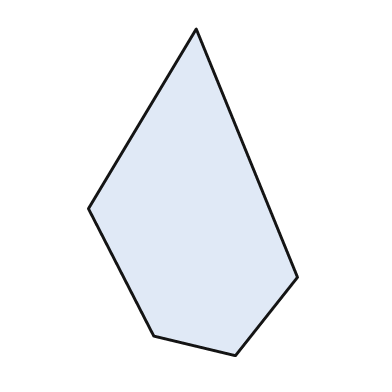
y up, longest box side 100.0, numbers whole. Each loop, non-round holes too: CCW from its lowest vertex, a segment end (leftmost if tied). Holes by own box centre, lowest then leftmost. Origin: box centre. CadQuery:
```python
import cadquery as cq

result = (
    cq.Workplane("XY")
    .moveTo(13.0, -50.0)
    .lineTo(32.0, -26.0)
    .lineTo(1.0, 50.0)
    .lineTo(-32.0, -5.0)
    .lineTo(-12.0, -44.0)
    .close()
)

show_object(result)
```